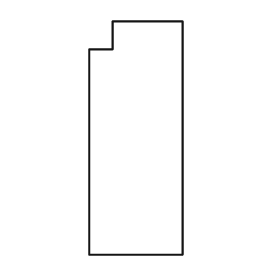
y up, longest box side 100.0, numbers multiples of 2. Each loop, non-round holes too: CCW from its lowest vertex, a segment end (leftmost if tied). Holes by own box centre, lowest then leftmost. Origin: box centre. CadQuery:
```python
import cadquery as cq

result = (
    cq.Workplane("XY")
    .moveTo(-20.0, -50.0)
    .lineTo(20.0, -50.0)
    .lineTo(20.0, 50.0)
    .lineTo(-10.0, 50.0)
    .lineTo(-10.0, 38.0)
    .lineTo(-20.0, 38.0)
    .close()
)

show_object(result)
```